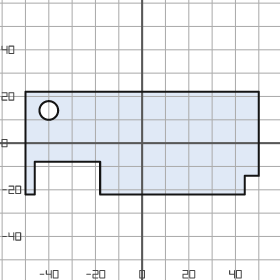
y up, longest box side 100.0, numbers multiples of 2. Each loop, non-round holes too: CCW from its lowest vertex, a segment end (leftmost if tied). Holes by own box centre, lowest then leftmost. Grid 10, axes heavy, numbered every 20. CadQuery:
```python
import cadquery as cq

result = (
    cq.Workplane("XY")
    .moveTo(-50.0, -22.0)
    .lineTo(-46.0, -22.0)
    .lineTo(-46.0, -8.0)
    .lineTo(-18.0, -8.0)
    .lineTo(-18.0, -22.0)
    .lineTo(44.0, -22.0)
    .lineTo(44.0, -14.0)
    .lineTo(50.0, -14.0)
    .lineTo(50.0, 22.0)
    .lineTo(-50.0, 22.0)
    .close()
    .moveTo(-40.0, 14.0)
    .circle(4.0)
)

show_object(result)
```